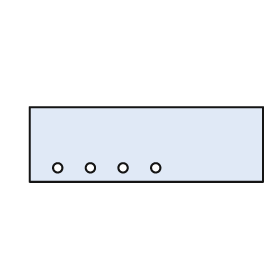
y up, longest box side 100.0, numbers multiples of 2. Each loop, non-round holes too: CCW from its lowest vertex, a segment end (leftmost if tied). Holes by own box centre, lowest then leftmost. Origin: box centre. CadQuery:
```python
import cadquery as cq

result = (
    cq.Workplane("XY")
    .moveTo(-50.0, -16.0)
    .lineTo(50.0, -16.0)
    .lineTo(50.0, 16.0)
    .lineTo(-50.0, 16.0)
    .close()
    .moveTo(-38.0, -10.0)
    .circle(2.0)
    .moveTo(-24.0, -10.0)
    .circle(2.0)
    .moveTo(-10.0, -10.0)
    .circle(2.0)
    .moveTo(4.0, -10.0)
    .circle(2.0)
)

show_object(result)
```